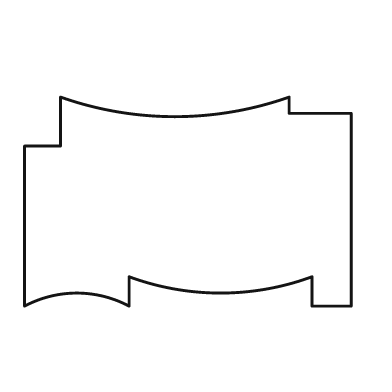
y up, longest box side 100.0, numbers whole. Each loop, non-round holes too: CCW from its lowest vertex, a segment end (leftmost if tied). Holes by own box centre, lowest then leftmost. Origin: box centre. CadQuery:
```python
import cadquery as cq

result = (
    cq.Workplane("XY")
    .moveTo(-50.0, -32.0)
    .threePointArc((-34.0, -28.0), (-18.0, -32.0))
    .lineTo(-18.0, -23.0)
    .threePointArc((10.0, -28.0), (38.0, -23.0))
    .lineTo(38.0, -32.0)
    .lineTo(50.0, -32.0)
    .lineTo(50.0, 27.0)
    .lineTo(31.0, 27.0)
    .lineTo(31.0, 32.0)
    .threePointArc((-4.0, 26.0), (-39.0, 32.0))
    .lineTo(-39.0, 17.0)
    .lineTo(-50.0, 17.0)
    .close()
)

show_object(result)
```